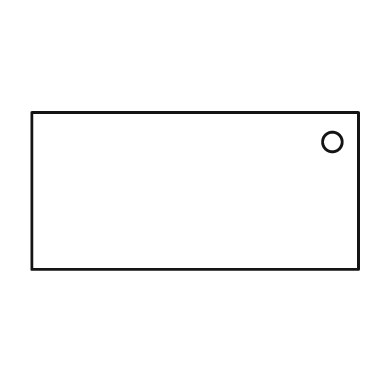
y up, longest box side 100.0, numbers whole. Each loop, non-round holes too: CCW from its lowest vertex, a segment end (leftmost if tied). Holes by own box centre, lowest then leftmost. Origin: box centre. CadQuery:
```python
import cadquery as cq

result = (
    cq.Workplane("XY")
    .moveTo(-50.0, -24.0)
    .lineTo(50.0, -24.0)
    .lineTo(50.0, 24.0)
    .lineTo(-50.0, 24.0)
    .close()
    .moveTo(42.0, 15.0)
    .circle(3.0)
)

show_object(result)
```